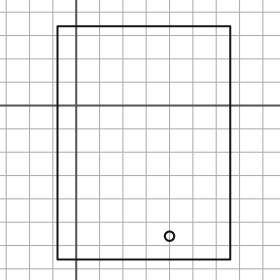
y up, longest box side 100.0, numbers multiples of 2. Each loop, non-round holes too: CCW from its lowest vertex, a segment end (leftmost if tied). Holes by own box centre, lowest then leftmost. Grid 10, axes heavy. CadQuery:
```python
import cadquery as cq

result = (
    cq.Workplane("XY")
    .moveTo(-8.0, -66.0)
    .lineTo(66.0, -66.0)
    .lineTo(66.0, 34.0)
    .lineTo(-8.0, 34.0)
    .close()
    .moveTo(40.0, -56.0)
    .circle(2.0)
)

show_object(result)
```